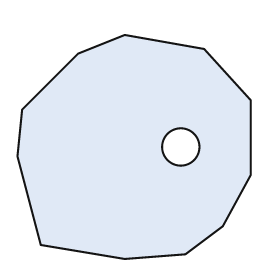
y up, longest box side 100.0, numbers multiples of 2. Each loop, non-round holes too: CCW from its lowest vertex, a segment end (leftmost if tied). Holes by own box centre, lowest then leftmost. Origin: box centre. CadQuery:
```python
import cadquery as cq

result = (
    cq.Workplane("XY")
    .moveTo(-4.0, -48.0)
    .lineTo(22.0, -46.0)
    .lineTo(38.0, -34.0)
    .lineTo(50.0, -12.0)
    .lineTo(50.0, 20.0)
    .lineTo(30.0, 42.0)
    .lineTo(-4.0, 48.0)
    .lineTo(-24.0, 40.0)
    .lineTo(-48.0, 16.0)
    .lineTo(-50.0, -4.0)
    .lineTo(-40.0, -42.0)
    .close()
    .moveTo(20.0, 0.0)
    .circle(8.0)
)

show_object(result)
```